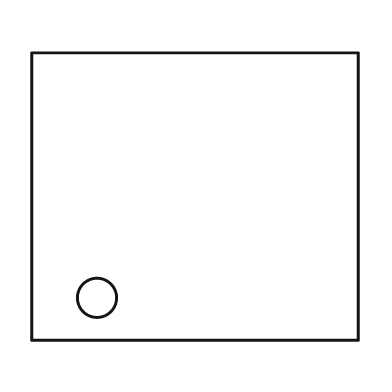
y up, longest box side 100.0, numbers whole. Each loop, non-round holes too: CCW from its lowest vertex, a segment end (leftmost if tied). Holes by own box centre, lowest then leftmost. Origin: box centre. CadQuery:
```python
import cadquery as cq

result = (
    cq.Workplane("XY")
    .moveTo(-50.0, -44.0)
    .lineTo(50.0, -44.0)
    .lineTo(50.0, 44.0)
    .lineTo(-50.0, 44.0)
    .close()
    .moveTo(-30.0, -31.0)
    .circle(6.0)
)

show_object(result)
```